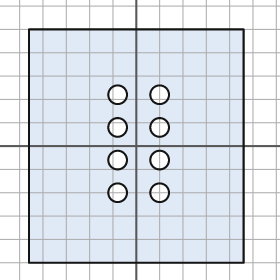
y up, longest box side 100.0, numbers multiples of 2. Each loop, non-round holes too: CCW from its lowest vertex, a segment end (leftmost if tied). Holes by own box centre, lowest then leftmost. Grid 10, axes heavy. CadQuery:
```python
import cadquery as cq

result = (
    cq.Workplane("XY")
    .moveTo(-46.0, -50.0)
    .lineTo(46.0, -50.0)
    .lineTo(46.0, 50.0)
    .lineTo(-46.0, 50.0)
    .close()
    .moveTo(-8.0, -20.0)
    .circle(4.0)
    .moveTo(10.0, -20.0)
    .circle(4.0)
    .moveTo(-8.0, -6.0)
    .circle(4.0)
    .moveTo(10.0, -6.0)
    .circle(4.0)
    .moveTo(-8.0, 8.0)
    .circle(4.0)
    .moveTo(10.0, 8.0)
    .circle(4.0)
    .moveTo(-8.0, 22.0)
    .circle(4.0)
    .moveTo(10.0, 22.0)
    .circle(4.0)
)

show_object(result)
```